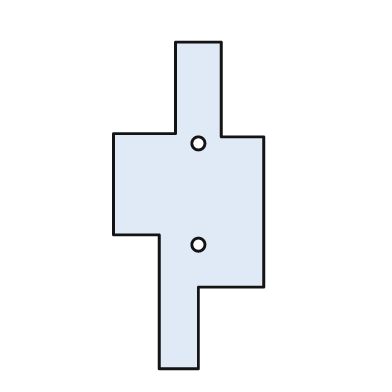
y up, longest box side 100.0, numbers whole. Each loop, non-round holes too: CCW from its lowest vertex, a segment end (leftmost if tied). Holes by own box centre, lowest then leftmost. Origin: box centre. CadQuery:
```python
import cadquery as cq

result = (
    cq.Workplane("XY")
    .moveTo(-9.0, -50.0)
    .lineTo(3.0, -50.0)
    .lineTo(3.0, -25.0)
    .lineTo(23.0, -25.0)
    .lineTo(23.0, 21.0)
    .lineTo(10.0, 21.0)
    .lineTo(10.0, 50.0)
    .lineTo(-4.0, 50.0)
    .lineTo(-4.0, 22.0)
    .lineTo(-23.0, 22.0)
    .lineTo(-23.0, -9.0)
    .lineTo(-9.0, -9.0)
    .close()
    .moveTo(3.0, -12.0)
    .circle(2.0)
    .moveTo(3.0, 19.0)
    .circle(2.0)
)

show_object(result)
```